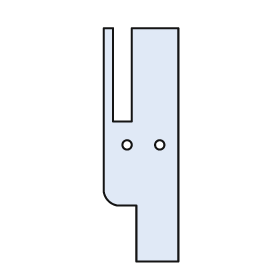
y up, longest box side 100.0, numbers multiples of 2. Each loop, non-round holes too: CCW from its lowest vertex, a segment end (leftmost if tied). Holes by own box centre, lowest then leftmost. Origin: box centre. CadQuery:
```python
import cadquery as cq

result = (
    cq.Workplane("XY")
    .moveTo(-2.0, -50.0)
    .lineTo(16.0, -50.0)
    .lineTo(16.0, 50.0)
    .lineTo(-4.0, 50.0)
    .lineTo(-4.0, 10.0)
    .lineTo(-12.0, 10.0)
    .lineTo(-12.0, 50.0)
    .lineTo(-16.0, 50.0)
    .lineTo(-16.0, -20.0)
    .threePointArc((-14.0, -24.0), (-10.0, -26.0))
    .lineTo(-2.0, -26.0)
    .close()
    .moveTo(-6.0, 0.0)
    .circle(2.0)
    .moveTo(8.0, 0.0)
    .circle(2.0)
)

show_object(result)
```